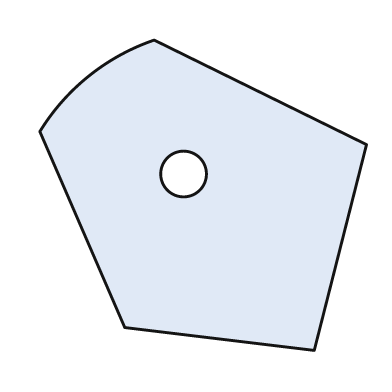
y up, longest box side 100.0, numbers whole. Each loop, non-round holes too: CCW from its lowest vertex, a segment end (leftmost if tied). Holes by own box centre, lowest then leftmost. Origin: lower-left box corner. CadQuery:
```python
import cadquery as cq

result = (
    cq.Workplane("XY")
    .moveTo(84.0, 0.0)
    .lineTo(100.0, 63.0)
    .lineTo(35.0, 95.0)
    .threePointArc((15.0, 84.0), (0.0, 67.0))
    .lineTo(26.0, 7.0)
    .close()
    .moveTo(44.0, 54.0)
    .circle(7.0)
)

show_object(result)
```